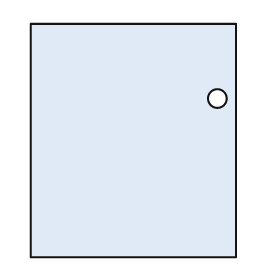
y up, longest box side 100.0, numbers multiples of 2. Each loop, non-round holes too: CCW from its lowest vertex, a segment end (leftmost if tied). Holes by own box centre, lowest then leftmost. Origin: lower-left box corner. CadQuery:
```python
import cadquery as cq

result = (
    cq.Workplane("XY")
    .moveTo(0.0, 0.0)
    .lineTo(88.0, 0.0)
    .lineTo(88.0, 100.0)
    .lineTo(0.0, 100.0)
    .close()
    .moveTo(80.0, 68.0)
    .circle(4.0)
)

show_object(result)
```